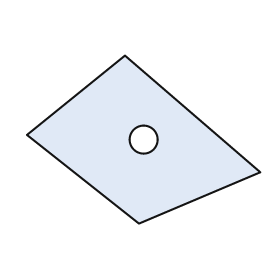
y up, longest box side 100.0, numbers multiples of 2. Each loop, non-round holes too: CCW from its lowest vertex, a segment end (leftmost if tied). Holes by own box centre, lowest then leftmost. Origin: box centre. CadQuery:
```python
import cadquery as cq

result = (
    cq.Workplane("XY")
    .moveTo(-2.0, -36.0)
    .lineTo(50.0, -14.0)
    .lineTo(-8.0, 36.0)
    .lineTo(-50.0, 2.0)
    .close()
    .moveTo(0.0, 0.0)
    .circle(6.0)
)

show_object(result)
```